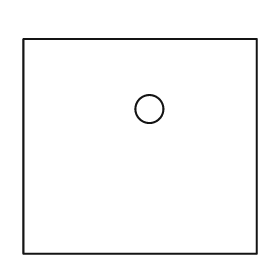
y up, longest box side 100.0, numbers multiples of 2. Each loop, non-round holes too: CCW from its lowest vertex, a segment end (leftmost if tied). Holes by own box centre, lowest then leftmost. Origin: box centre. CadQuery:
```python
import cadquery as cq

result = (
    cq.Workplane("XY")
    .moveTo(-50.0, -46.0)
    .lineTo(50.0, -46.0)
    .lineTo(50.0, 46.0)
    .lineTo(-50.0, 46.0)
    .close()
    .moveTo(4.0, 16.0)
    .circle(6.0)
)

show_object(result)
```